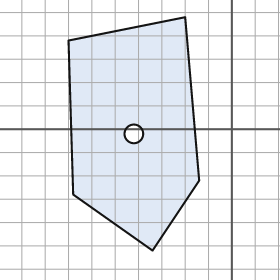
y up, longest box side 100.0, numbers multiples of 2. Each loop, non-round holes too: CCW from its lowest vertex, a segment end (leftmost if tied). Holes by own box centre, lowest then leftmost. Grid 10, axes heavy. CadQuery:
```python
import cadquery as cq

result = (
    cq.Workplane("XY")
    .moveTo(-34.0, -52.0)
    .lineTo(-14.0, -22.0)
    .lineTo(-20.0, 48.0)
    .lineTo(-70.0, 38.0)
    .lineTo(-68.0, -28.0)
    .close()
    .moveTo(-42.0, -2.0)
    .circle(4.0)
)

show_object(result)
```